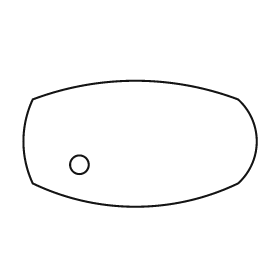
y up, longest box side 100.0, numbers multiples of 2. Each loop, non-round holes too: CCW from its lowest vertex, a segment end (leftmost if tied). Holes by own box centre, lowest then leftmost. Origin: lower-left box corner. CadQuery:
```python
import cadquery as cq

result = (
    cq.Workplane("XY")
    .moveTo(4.0, 10.0)
    .threePointArc((48.0, 0.0), (92.0, 10.0))
    .threePointArc((100.0, 28.0), (92.0, 46.0))
    .threePointArc((48.0, 54.0), (4.0, 46.0))
    .threePointArc((0.0, 28.0), (4.0, 10.0))
    .close()
    .moveTo(24.0, 18.0)
    .circle(4.0)
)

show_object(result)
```